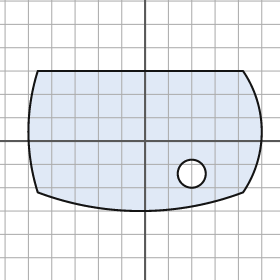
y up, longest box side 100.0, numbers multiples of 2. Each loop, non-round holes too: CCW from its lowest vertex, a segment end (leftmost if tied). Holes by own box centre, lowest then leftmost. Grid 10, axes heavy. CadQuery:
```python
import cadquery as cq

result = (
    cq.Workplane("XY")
    .moveTo(-46.0, -22.0)
    .threePointArc((-2.0, -30.0), (42.0, -22.0))
    .threePointArc((50.0, 4.0), (42.0, 30.0))
    .lineTo(-46.0, 30.0)
    .threePointArc((-50.0, 4.0), (-46.0, -22.0))
    .close()
    .moveTo(20.0, -14.0)
    .circle(6.0)
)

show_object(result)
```